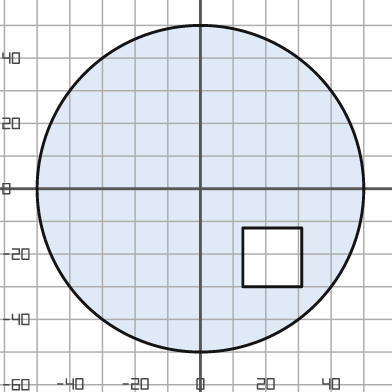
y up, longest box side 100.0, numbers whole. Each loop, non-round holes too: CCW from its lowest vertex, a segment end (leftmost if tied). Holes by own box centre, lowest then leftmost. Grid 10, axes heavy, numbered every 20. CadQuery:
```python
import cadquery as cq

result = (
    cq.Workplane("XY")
    .moveTo(0.0, 0.0)
    .circle(50.0)
    .moveTo(13.0, -30.0)
    .lineTo(31.0, -30.0)
    .lineTo(31.0, -12.0)
    .lineTo(13.0, -12.0)
    .close()
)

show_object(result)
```